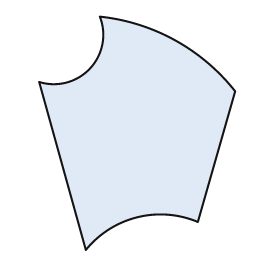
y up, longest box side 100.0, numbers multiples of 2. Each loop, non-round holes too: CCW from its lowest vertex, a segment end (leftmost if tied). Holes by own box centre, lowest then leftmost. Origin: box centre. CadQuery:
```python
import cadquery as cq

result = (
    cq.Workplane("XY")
    .moveTo(-22.0, -50.0)
    .threePointArc((0.0, -36.0), (26.0, -38.0))
    .lineTo(42.0, 18.0)
    .threePointArc((16.0, 40.0), (-16.0, 50.0))
    .threePointArc((-20.0, 28.0), (-42.0, 22.0))
    .close()
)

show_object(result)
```